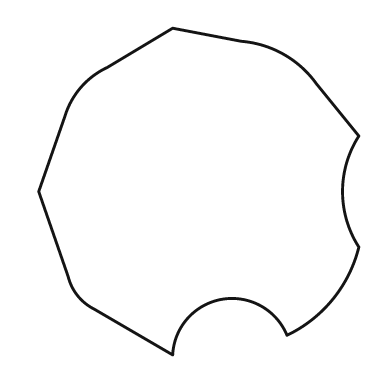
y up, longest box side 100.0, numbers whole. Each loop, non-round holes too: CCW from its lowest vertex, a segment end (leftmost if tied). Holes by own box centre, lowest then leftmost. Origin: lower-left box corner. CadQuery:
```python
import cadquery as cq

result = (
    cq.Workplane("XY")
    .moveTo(41.0, 0.0)
    .threePointArc((56.0, 17.0), (76.0, 6.0))
    .threePointArc((90.0, 17.0), (98.0, 33.0))
    .threePointArc((93.0, 50.0), (98.0, 67.0))
    .lineTo(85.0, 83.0)
    .threePointArc((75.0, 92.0), (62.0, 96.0))
    .lineTo(41.0, 100.0)
    .lineTo(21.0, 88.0)
    .threePointArc((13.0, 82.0), (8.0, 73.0))
    .lineTo(0.0, 50.0)
    .lineTo(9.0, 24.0)
    .threePointArc((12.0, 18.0), (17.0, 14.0))
    .close()
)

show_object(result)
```